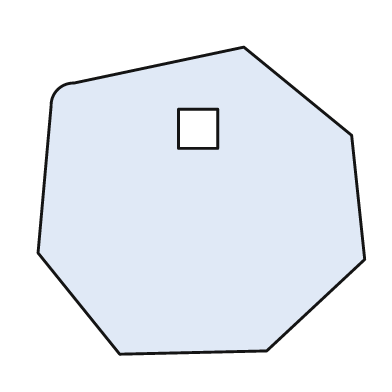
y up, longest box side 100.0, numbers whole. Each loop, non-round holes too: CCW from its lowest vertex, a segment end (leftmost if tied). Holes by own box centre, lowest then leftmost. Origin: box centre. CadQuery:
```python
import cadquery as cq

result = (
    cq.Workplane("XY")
    .moveTo(-25.0, -47.0)
    .lineTo(20.0, -46.0)
    .lineTo(50.0, -18.0)
    .lineTo(46.0, 20.0)
    .lineTo(13.0, 47.0)
    .lineTo(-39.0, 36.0)
    .threePointArc((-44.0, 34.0), (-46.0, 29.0))
    .lineTo(-50.0, -16.0)
    .close()
    .moveTo(-7.0, 16.0)
    .lineTo(5.0, 16.0)
    .lineTo(5.0, 28.0)
    .lineTo(-7.0, 28.0)
    .close()
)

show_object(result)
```